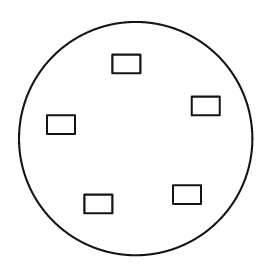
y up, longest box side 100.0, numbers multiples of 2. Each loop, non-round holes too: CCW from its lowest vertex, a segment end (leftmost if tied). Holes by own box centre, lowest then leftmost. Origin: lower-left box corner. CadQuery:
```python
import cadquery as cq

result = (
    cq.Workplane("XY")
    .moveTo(50.0, 50.0)
    .circle(50.0)
    .moveTo(28.0, 18.0)
    .lineTo(40.0, 18.0)
    .lineTo(40.0, 26.0)
    .lineTo(28.0, 26.0)
    .close()
    .moveTo(66.0, 22.0)
    .lineTo(78.0, 22.0)
    .lineTo(78.0, 30.0)
    .lineTo(66.0, 30.0)
    .close()
    .moveTo(12.0, 52.0)
    .lineTo(24.0, 52.0)
    .lineTo(24.0, 60.0)
    .lineTo(12.0, 60.0)
    .close()
    .moveTo(74.0, 60.0)
    .lineTo(86.0, 60.0)
    .lineTo(86.0, 68.0)
    .lineTo(74.0, 68.0)
    .close()
    .moveTo(40.0, 78.0)
    .lineTo(52.0, 78.0)
    .lineTo(52.0, 86.0)
    .lineTo(40.0, 86.0)
    .close()
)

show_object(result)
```